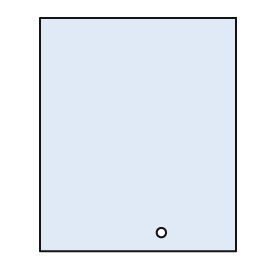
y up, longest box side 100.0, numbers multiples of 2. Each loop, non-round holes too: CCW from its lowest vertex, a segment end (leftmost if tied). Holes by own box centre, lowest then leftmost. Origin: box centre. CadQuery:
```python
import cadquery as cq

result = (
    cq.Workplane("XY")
    .moveTo(-42.0, -50.0)
    .lineTo(42.0, -50.0)
    .lineTo(42.0, 50.0)
    .lineTo(-42.0, 50.0)
    .close()
    .moveTo(10.0, -42.0)
    .circle(2.0)
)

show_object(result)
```